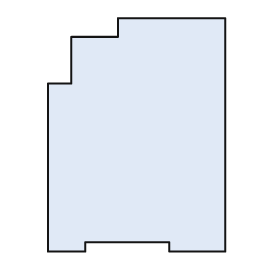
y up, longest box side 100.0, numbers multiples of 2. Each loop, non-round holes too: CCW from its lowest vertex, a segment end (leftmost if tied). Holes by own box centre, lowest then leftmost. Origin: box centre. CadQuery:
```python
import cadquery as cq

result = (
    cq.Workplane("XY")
    .moveTo(-38.0, -50.0)
    .lineTo(-22.0, -50.0)
    .lineTo(-22.0, -46.0)
    .lineTo(14.0, -46.0)
    .lineTo(14.0, -50.0)
    .lineTo(38.0, -50.0)
    .lineTo(38.0, 50.0)
    .lineTo(-8.0, 50.0)
    .lineTo(-8.0, 42.0)
    .lineTo(-28.0, 42.0)
    .lineTo(-28.0, 22.0)
    .lineTo(-38.0, 22.0)
    .close()
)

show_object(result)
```